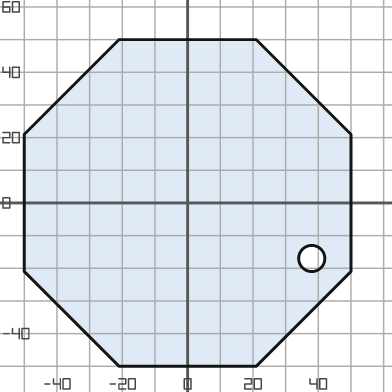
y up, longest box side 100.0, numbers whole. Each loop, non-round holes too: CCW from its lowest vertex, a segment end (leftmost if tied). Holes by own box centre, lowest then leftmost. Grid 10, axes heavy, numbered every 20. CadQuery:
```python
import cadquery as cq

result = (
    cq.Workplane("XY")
    .moveTo(-21.0, -50.0)
    .lineTo(21.0, -50.0)
    .lineTo(50.0, -21.0)
    .lineTo(50.0, 21.0)
    .lineTo(21.0, 50.0)
    .lineTo(-21.0, 50.0)
    .lineTo(-50.0, 21.0)
    .lineTo(-50.0, -21.0)
    .close()
    .moveTo(38.0, -17.0)
    .circle(4.0)
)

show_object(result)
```